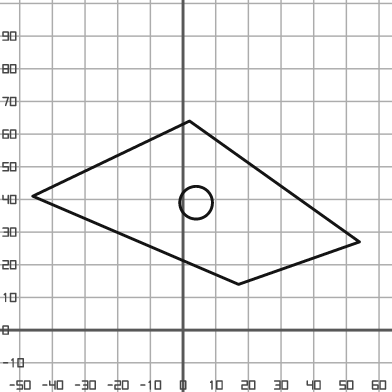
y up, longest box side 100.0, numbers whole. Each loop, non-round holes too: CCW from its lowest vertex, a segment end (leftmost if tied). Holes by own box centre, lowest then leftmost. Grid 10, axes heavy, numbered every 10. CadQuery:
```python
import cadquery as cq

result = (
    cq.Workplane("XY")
    .moveTo(17.0, 14.0)
    .lineTo(54.0, 27.0)
    .lineTo(2.0, 64.0)
    .lineTo(-46.0, 41.0)
    .close()
    .moveTo(4.0, 39.0)
    .circle(5.0)
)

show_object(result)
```